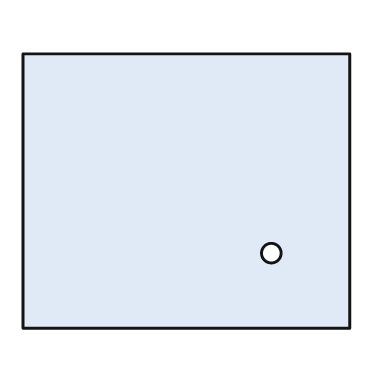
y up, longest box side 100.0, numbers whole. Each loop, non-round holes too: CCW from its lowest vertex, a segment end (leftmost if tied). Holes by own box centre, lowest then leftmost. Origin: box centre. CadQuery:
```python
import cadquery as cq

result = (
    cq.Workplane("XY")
    .moveTo(-50.0, -42.0)
    .lineTo(50.0, -42.0)
    .lineTo(50.0, 42.0)
    .lineTo(-50.0, 42.0)
    .close()
    .moveTo(26.0, -19.0)
    .circle(3.0)
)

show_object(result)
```